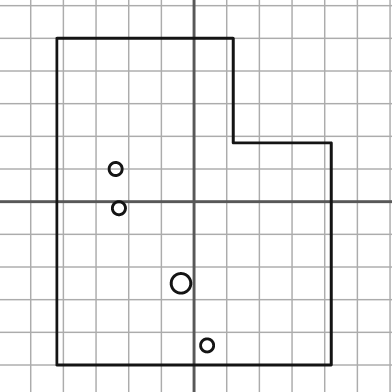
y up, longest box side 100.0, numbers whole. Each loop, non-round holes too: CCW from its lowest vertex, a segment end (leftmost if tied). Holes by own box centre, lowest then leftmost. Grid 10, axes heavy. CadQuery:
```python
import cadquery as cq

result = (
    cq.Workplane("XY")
    .moveTo(-42.0, -50.0)
    .lineTo(42.0, -50.0)
    .lineTo(42.0, 18.0)
    .lineTo(12.0, 18.0)
    .lineTo(12.0, 50.0)
    .lineTo(-42.0, 50.0)
    .close()
    .moveTo(4.0, -44.0)
    .circle(2.0)
    .moveTo(-4.0, -25.0)
    .circle(3.0)
    .moveTo(-23.0, -2.0)
    .circle(2.0)
    .moveTo(-24.0, 10.0)
    .circle(2.0)
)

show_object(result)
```